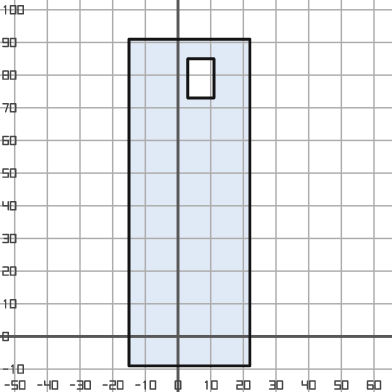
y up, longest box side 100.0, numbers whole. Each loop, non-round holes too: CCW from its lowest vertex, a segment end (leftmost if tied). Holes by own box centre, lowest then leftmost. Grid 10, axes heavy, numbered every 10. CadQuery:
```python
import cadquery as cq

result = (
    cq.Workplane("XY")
    .moveTo(-15.0, -9.0)
    .lineTo(22.0, -9.0)
    .lineTo(22.0, 91.0)
    .lineTo(-15.0, 91.0)
    .close()
    .moveTo(3.0, 73.0)
    .lineTo(11.0, 73.0)
    .lineTo(11.0, 85.0)
    .lineTo(3.0, 85.0)
    .close()
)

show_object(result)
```